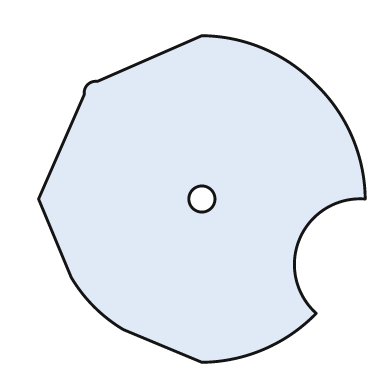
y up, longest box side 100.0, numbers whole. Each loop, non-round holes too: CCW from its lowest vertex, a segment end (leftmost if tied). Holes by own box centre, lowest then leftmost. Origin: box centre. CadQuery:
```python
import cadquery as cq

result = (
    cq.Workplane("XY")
    .moveTo(0.0, -50.0)
    .threePointArc((19.0, -46.0), (35.0, -35.0))
    .threePointArc((30.0, -12.0), (50.0, 0.0))
    .threePointArc((46.0, 19.0), (35.0, 35.0))
    .threePointArc((19.0, 46.0), (0.0, 50.0))
    .lineTo(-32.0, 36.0)
    .threePointArc((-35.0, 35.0), (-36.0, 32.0))
    .lineTo(-50.0, 0.0)
    .lineTo(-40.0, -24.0)
    .threePointArc((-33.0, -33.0), (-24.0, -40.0))
    .close()
    .moveTo(0.0, 0.0)
    .circle(4.0)
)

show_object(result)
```